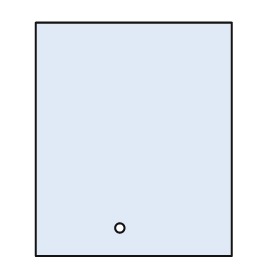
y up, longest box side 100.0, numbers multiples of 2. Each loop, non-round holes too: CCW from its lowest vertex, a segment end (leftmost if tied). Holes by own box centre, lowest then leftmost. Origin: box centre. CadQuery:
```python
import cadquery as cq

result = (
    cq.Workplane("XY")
    .moveTo(-42.0, -50.0)
    .lineTo(42.0, -50.0)
    .lineTo(42.0, 50.0)
    .lineTo(-42.0, 50.0)
    .close()
    .moveTo(-6.0, -38.0)
    .circle(2.0)
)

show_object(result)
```